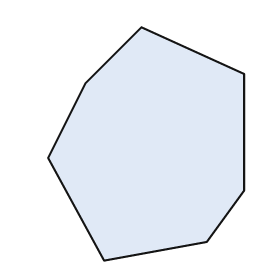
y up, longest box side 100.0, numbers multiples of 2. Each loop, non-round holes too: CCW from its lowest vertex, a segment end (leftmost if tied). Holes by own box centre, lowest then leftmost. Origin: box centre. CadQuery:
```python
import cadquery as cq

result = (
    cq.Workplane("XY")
    .moveTo(-18.0, -50.0)
    .lineTo(26.0, -42.0)
    .lineTo(42.0, -20.0)
    .lineTo(42.0, 30.0)
    .lineTo(-2.0, 50.0)
    .lineTo(-26.0, 26.0)
    .lineTo(-42.0, -6.0)
    .close()
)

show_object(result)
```